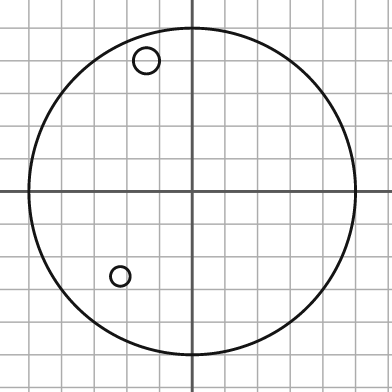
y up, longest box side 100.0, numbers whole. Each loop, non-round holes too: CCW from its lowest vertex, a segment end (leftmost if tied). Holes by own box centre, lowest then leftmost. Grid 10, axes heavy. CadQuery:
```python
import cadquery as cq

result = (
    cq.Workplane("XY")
    .moveTo(0.0, 0.0)
    .circle(50.0)
    .moveTo(-22.0, -26.0)
    .circle(3.0)
    .moveTo(-14.0, 40.0)
    .circle(4.0)
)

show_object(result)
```